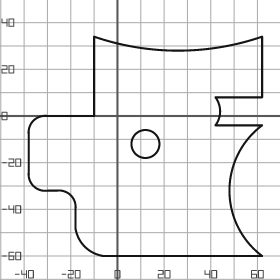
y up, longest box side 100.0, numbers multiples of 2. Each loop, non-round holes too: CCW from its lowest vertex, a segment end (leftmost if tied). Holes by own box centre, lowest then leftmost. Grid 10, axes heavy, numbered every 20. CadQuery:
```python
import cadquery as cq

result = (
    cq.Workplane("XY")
    .moveTo(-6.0, -60.0)
    .lineTo(62.0, -60.0)
    .threePointArc((48.0, -32.0), (62.0, -4.0))
    .lineTo(42.0, -4.0)
    .threePointArc((44.0, 2.0), (42.0, 8.0))
    .lineTo(62.0, 8.0)
    .lineTo(62.0, 34.0)
    .threePointArc((26.0, 28.0), (-10.0, 34.0))
    .lineTo(-10.0, 0.0)
    .lineTo(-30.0, 0.0)
    .threePointArc((-36.0, -2.0), (-38.0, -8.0))
    .lineTo(-38.0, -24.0)
    .threePointArc((-36.0, -30.0), (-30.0, -32.0))
    .lineTo(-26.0, -32.0)
    .threePointArc((-20.0, -34.0), (-18.0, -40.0))
    .lineTo(-18.0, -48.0)
    .threePointArc((-14.0, -56.0), (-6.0, -60.0))
    .close()
    .moveTo(12.0, -12.0)
    .circle(6.0)
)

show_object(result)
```